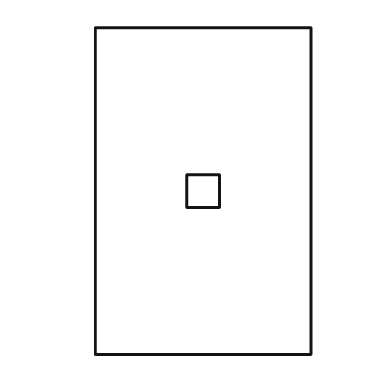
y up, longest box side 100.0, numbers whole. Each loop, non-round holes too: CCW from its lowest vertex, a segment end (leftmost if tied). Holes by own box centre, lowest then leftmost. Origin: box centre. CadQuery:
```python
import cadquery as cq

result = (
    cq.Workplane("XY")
    .moveTo(-33.0, -50.0)
    .lineTo(33.0, -50.0)
    .lineTo(33.0, 50.0)
    .lineTo(-33.0, 50.0)
    .close()
    .moveTo(-5.0, -5.0)
    .lineTo(5.0, -5.0)
    .lineTo(5.0, 5.0)
    .lineTo(-5.0, 5.0)
    .close()
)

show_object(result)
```